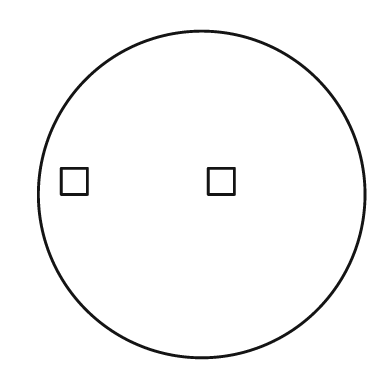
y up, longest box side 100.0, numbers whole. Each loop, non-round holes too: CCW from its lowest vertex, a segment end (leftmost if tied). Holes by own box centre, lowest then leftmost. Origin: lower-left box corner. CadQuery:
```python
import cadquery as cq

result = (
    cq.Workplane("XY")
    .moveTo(50.0, 50.0)
    .circle(50.0)
    .moveTo(7.0, 50.0)
    .lineTo(15.0, 50.0)
    .lineTo(15.0, 58.0)
    .lineTo(7.0, 58.0)
    .close()
    .moveTo(52.0, 50.0)
    .lineTo(60.0, 50.0)
    .lineTo(60.0, 58.0)
    .lineTo(52.0, 58.0)
    .close()
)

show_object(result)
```